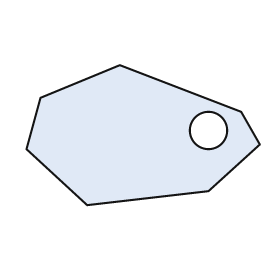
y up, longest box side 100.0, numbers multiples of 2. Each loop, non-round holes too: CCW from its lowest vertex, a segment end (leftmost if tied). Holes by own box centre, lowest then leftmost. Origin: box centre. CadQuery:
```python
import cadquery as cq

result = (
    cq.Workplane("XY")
    .moveTo(-24.0, -30.0)
    .lineTo(28.0, -24.0)
    .lineTo(50.0, -4.0)
    .lineTo(42.0, 10.0)
    .lineTo(-10.0, 30.0)
    .lineTo(-44.0, 16.0)
    .lineTo(-50.0, -6.0)
    .close()
    .moveTo(28.0, 2.0)
    .circle(8.0)
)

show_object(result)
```